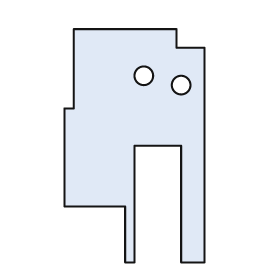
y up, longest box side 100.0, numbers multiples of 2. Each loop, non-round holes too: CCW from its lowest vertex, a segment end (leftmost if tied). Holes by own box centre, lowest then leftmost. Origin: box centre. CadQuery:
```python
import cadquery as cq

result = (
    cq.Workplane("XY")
    .moveTo(-4.0, -50.0)
    .lineTo(0.0, -50.0)
    .lineTo(0.0, 0.0)
    .lineTo(20.0, 0.0)
    .lineTo(20.0, -50.0)
    .lineTo(30.0, -50.0)
    .lineTo(30.0, 42.0)
    .lineTo(18.0, 42.0)
    .lineTo(18.0, 50.0)
    .lineTo(-26.0, 50.0)
    .lineTo(-26.0, 16.0)
    .lineTo(-30.0, 16.0)
    .lineTo(-30.0, -26.0)
    .lineTo(-4.0, -26.0)
    .close()
    .moveTo(20.0, 26.0)
    .circle(4.0)
    .moveTo(4.0, 30.0)
    .circle(4.0)
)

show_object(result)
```